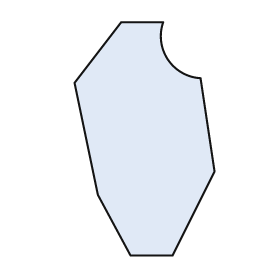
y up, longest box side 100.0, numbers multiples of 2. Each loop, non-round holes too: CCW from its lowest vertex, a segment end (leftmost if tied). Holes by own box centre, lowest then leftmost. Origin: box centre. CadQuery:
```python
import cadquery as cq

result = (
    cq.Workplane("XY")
    .moveTo(-6.0, -50.0)
    .lineTo(12.0, -50.0)
    .lineTo(30.0, -14.0)
    .lineTo(24.0, 26.0)
    .threePointArc((10.0, 34.0), (8.0, 50.0))
    .lineTo(-10.0, 50.0)
    .lineTo(-30.0, 24.0)
    .lineTo(-20.0, -24.0)
    .close()
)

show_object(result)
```